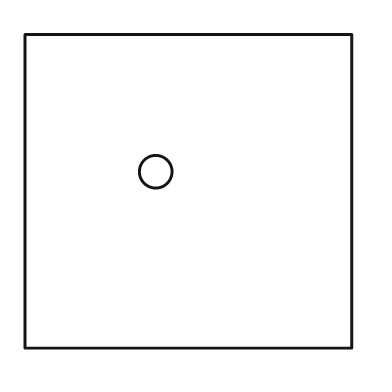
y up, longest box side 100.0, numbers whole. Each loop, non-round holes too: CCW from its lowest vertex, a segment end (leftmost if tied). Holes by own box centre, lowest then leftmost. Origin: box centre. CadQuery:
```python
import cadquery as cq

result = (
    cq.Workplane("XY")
    .moveTo(-50.0, -48.0)
    .lineTo(50.0, -48.0)
    .lineTo(50.0, 48.0)
    .lineTo(-50.0, 48.0)
    .close()
    .moveTo(-10.0, 6.0)
    .circle(5.0)
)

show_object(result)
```